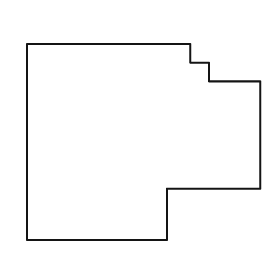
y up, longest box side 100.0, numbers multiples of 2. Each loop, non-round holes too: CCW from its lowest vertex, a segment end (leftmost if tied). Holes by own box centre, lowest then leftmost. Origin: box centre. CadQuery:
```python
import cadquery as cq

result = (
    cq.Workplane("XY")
    .moveTo(-50.0, -42.0)
    .lineTo(10.0, -42.0)
    .lineTo(10.0, -20.0)
    .lineTo(50.0, -20.0)
    .lineTo(50.0, 26.0)
    .lineTo(28.0, 26.0)
    .lineTo(28.0, 34.0)
    .lineTo(20.0, 34.0)
    .lineTo(20.0, 42.0)
    .lineTo(-50.0, 42.0)
    .close()
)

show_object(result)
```